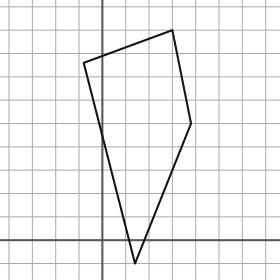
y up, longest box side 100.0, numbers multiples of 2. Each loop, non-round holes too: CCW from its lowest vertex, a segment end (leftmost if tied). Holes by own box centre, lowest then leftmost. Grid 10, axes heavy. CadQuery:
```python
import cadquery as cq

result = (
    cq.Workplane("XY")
    .moveTo(14.0, -10.0)
    .lineTo(38.0, 50.0)
    .lineTo(30.0, 90.0)
    .lineTo(-8.0, 76.0)
    .close()
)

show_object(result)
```